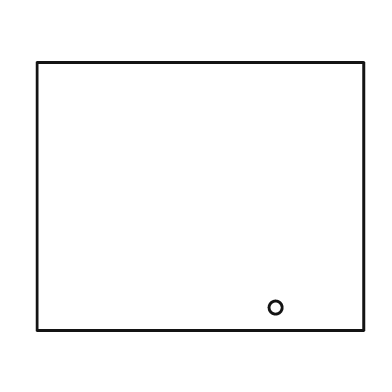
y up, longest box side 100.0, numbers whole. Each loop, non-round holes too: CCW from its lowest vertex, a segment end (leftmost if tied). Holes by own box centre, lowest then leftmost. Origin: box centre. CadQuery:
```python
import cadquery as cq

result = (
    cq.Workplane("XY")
    .moveTo(-50.0, -41.0)
    .lineTo(50.0, -41.0)
    .lineTo(50.0, 41.0)
    .lineTo(-50.0, 41.0)
    .close()
    .moveTo(23.0, -34.0)
    .circle(2.0)
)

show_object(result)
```